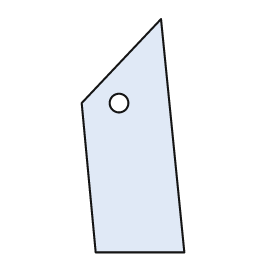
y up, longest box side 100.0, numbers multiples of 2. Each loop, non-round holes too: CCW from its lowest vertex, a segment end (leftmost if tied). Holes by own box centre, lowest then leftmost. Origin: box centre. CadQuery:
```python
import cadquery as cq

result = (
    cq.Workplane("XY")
    .moveTo(-16.0, -50.0)
    .lineTo(22.0, -50.0)
    .lineTo(12.0, 50.0)
    .lineTo(-22.0, 14.0)
    .close()
    .moveTo(-6.0, 14.0)
    .circle(4.0)
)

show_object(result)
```